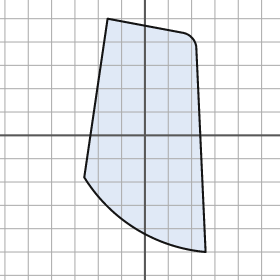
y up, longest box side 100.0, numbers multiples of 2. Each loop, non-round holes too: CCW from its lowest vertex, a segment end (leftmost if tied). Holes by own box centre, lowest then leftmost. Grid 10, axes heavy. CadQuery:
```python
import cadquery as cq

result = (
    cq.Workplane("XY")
    .moveTo(26.0, -50.0)
    .lineTo(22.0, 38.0)
    .threePointArc((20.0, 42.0), (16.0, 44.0))
    .lineTo(-16.0, 50.0)
    .lineTo(-26.0, -18.0)
    .threePointArc((-4.0, -40.0), (26.0, -50.0))
    .close()
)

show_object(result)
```